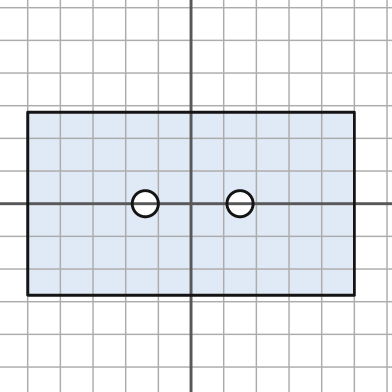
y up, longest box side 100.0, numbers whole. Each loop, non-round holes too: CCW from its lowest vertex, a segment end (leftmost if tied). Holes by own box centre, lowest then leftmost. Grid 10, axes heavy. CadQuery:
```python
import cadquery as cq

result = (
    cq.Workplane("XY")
    .moveTo(-50.0, -28.0)
    .lineTo(50.0, -28.0)
    .lineTo(50.0, 28.0)
    .lineTo(-50.0, 28.0)
    .close()
    .moveTo(-14.0, 0.0)
    .circle(4.0)
    .moveTo(15.0, 0.0)
    .circle(4.0)
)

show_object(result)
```